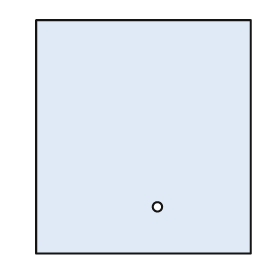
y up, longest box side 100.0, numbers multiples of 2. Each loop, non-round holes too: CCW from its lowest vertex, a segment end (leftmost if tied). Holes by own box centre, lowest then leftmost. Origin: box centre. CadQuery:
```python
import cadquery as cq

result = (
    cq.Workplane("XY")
    .moveTo(-46.0, -50.0)
    .lineTo(46.0, -50.0)
    .lineTo(46.0, 50.0)
    .lineTo(-46.0, 50.0)
    .close()
    .moveTo(6.0, -30.0)
    .circle(2.0)
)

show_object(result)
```